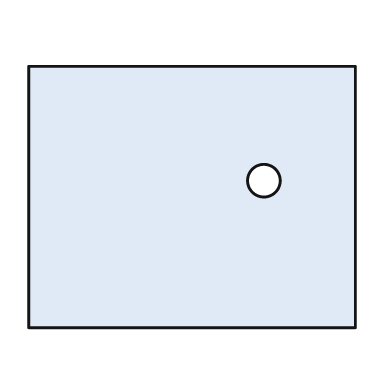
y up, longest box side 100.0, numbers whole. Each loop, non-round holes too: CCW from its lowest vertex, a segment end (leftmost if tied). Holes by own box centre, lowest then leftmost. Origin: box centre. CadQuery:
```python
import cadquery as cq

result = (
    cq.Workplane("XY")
    .moveTo(-50.0, -40.0)
    .lineTo(50.0, -40.0)
    .lineTo(50.0, 40.0)
    .lineTo(-50.0, 40.0)
    .close()
    .moveTo(22.0, 5.0)
    .circle(5.0)
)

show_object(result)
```